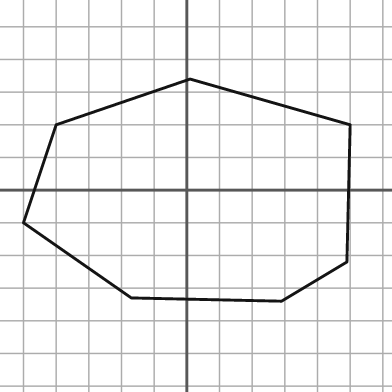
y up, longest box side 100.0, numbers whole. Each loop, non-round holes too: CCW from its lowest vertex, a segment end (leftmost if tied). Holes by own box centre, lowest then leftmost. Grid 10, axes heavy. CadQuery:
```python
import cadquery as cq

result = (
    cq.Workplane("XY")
    .moveTo(29.0, -34.0)
    .lineTo(49.0, -22.0)
    .lineTo(50.0, 20.0)
    .lineTo(1.0, 34.0)
    .lineTo(-40.0, 20.0)
    .lineTo(-50.0, -10.0)
    .lineTo(-17.0, -33.0)
    .close()
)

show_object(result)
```